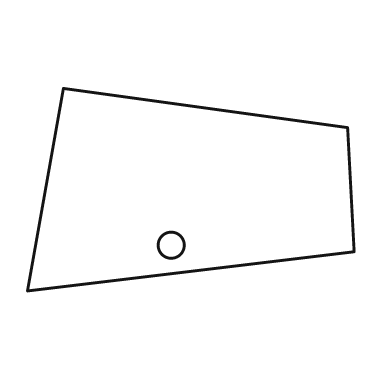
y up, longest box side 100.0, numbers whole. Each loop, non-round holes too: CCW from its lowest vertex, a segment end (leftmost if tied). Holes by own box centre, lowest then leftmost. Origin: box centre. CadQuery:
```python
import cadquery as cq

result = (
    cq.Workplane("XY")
    .moveTo(-50.0, -31.0)
    .lineTo(50.0, -19.0)
    .lineTo(48.0, 19.0)
    .lineTo(-39.0, 31.0)
    .close()
    .moveTo(-6.0, -17.0)
    .circle(4.0)
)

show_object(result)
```